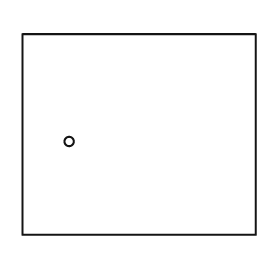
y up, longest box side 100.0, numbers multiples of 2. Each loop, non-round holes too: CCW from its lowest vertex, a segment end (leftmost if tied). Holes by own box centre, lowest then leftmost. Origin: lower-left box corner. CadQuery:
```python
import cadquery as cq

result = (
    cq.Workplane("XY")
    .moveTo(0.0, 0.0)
    .lineTo(100.0, 0.0)
    .lineTo(100.0, 86.0)
    .lineTo(0.0, 86.0)
    .close()
    .moveTo(20.0, 40.0)
    .circle(2.0)
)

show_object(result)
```